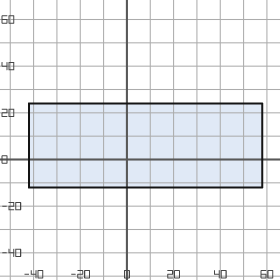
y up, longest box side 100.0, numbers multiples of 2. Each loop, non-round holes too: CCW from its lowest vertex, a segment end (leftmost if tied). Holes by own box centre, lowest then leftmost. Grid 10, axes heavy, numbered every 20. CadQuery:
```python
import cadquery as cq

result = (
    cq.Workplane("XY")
    .moveTo(-42.0, -12.0)
    .lineTo(58.0, -12.0)
    .lineTo(58.0, 24.0)
    .lineTo(-42.0, 24.0)
    .close()
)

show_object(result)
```